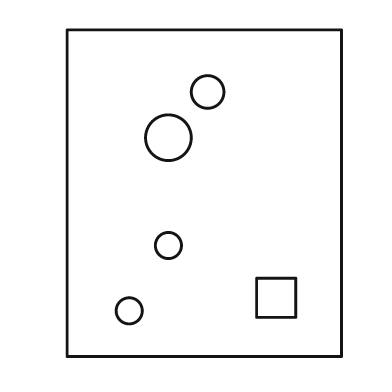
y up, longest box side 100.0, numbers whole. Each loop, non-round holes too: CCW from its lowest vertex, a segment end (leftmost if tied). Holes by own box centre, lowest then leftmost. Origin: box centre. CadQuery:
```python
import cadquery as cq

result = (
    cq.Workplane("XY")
    .moveTo(-42.0, -50.0)
    .lineTo(42.0, -50.0)
    .lineTo(42.0, 50.0)
    .lineTo(-42.0, 50.0)
    .close()
    .moveTo(-23.0, -36.0)
    .circle(4.0)
    .moveTo(16.0, -38.0)
    .lineTo(28.0, -38.0)
    .lineTo(28.0, -26.0)
    .lineTo(16.0, -26.0)
    .close()
    .moveTo(-11.0, -16.0)
    .circle(4.0)
    .moveTo(-11.0, 17.0)
    .circle(7.0)
    .moveTo(1.0, 31.0)
    .circle(5.0)
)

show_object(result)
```